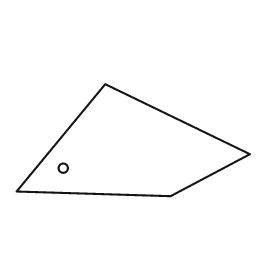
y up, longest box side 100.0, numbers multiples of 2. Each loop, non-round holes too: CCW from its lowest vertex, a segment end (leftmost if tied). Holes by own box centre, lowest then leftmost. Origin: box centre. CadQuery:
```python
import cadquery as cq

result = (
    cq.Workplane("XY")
    .moveTo(16.0, -24.0)
    .lineTo(50.0, -6.0)
    .lineTo(-12.0, 24.0)
    .lineTo(-50.0, -22.0)
    .close()
    .moveTo(-30.0, -12.0)
    .circle(2.0)
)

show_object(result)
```